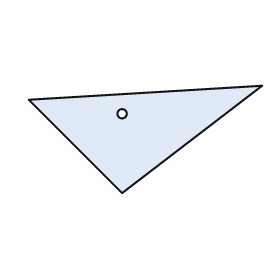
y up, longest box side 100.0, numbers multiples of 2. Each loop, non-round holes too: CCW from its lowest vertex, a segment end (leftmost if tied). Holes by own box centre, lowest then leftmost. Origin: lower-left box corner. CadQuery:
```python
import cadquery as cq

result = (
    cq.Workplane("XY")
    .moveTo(40.0, 0.0)
    .lineTo(100.0, 46.0)
    .lineTo(0.0, 40.0)
    .close()
    .moveTo(40.0, 34.0)
    .circle(2.0)
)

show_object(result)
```